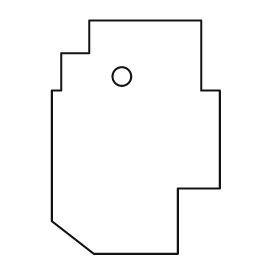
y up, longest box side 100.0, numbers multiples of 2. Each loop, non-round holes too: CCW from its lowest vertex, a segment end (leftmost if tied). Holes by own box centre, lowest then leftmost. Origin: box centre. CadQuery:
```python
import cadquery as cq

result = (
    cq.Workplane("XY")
    .moveTo(-18.0, -50.0)
    .lineTo(18.0, -50.0)
    .lineTo(18.0, -22.0)
    .lineTo(36.0, -22.0)
    .lineTo(36.0, 20.0)
    .lineTo(28.0, 20.0)
    .lineTo(28.0, 50.0)
    .lineTo(-20.0, 50.0)
    .lineTo(-20.0, 36.0)
    .lineTo(-32.0, 36.0)
    .lineTo(-32.0, 20.0)
    .lineTo(-36.0, 20.0)
    .lineTo(-36.0, -36.0)
    .close()
    .moveTo(-6.0, 26.0)
    .circle(4.0)
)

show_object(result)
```